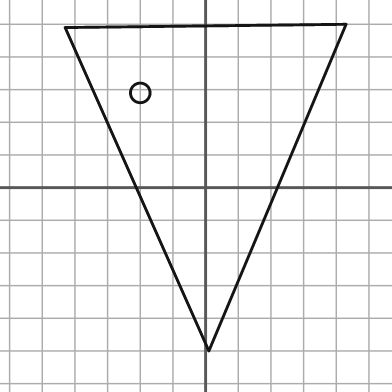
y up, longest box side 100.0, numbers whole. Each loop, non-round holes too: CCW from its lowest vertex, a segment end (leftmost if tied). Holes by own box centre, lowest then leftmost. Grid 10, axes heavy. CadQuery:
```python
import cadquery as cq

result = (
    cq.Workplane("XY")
    .moveTo(1.0, -50.0)
    .lineTo(43.0, 50.0)
    .lineTo(-43.0, 49.0)
    .close()
    .moveTo(-20.0, 29.0)
    .circle(3.0)
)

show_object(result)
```